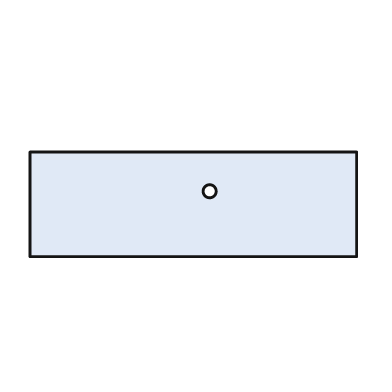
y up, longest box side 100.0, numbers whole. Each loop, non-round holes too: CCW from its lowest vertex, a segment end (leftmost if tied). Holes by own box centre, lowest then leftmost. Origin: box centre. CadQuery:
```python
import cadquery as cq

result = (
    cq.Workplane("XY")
    .moveTo(-50.0, -16.0)
    .lineTo(50.0, -16.0)
    .lineTo(50.0, 16.0)
    .lineTo(-50.0, 16.0)
    .close()
    .moveTo(5.0, 4.0)
    .circle(2.0)
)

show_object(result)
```